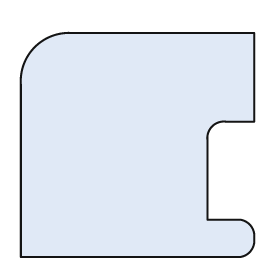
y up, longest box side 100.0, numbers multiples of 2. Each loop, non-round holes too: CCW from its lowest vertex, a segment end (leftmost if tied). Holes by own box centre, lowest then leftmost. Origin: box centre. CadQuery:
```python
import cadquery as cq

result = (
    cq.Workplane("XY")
    .moveTo(-50.0, -48.0)
    .lineTo(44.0, -48.0)
    .threePointArc((48.0, -46.0), (50.0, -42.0))
    .lineTo(50.0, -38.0)
    .threePointArc((48.0, -34.0), (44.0, -32.0))
    .lineTo(30.0, -32.0)
    .lineTo(30.0, 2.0)
    .threePointArc((32.0, 8.0), (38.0, 10.0))
    .lineTo(50.0, 10.0)
    .lineTo(50.0, 48.0)
    .lineTo(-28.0, 48.0)
    .threePointArc((-44.0, 42.0), (-50.0, 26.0))
    .close()
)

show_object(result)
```